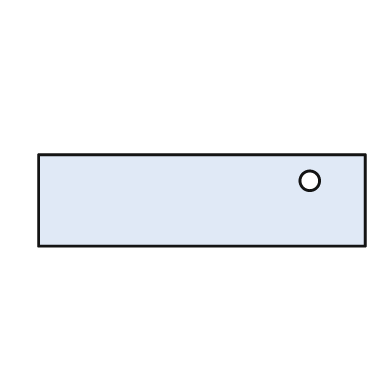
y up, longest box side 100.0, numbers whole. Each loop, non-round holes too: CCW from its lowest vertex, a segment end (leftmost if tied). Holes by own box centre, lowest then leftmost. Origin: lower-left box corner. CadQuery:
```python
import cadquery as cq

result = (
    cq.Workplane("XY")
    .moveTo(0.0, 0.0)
    .lineTo(100.0, 0.0)
    .lineTo(100.0, 28.0)
    .lineTo(0.0, 28.0)
    .close()
    .moveTo(83.0, 20.0)
    .circle(3.0)
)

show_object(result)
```